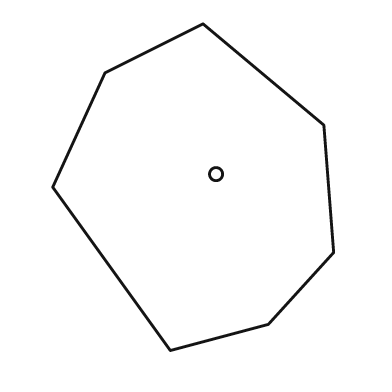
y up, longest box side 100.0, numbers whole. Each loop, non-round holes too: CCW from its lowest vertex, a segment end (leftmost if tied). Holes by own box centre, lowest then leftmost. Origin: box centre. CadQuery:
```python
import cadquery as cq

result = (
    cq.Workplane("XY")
    .moveTo(-7.0, -50.0)
    .lineTo(23.0, -42.0)
    .lineTo(43.0, -20.0)
    .lineTo(40.0, 19.0)
    .lineTo(3.0, 50.0)
    .lineTo(-27.0, 35.0)
    .lineTo(-43.0, 0.0)
    .close()
    .moveTo(7.0, 4.0)
    .circle(2.0)
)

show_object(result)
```